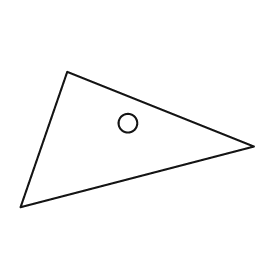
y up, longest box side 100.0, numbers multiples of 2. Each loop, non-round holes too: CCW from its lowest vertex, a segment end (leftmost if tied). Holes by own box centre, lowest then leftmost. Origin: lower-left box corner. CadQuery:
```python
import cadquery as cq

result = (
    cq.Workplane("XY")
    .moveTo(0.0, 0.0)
    .lineTo(100.0, 26.0)
    .lineTo(20.0, 58.0)
    .close()
    .moveTo(46.0, 36.0)
    .circle(4.0)
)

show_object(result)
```